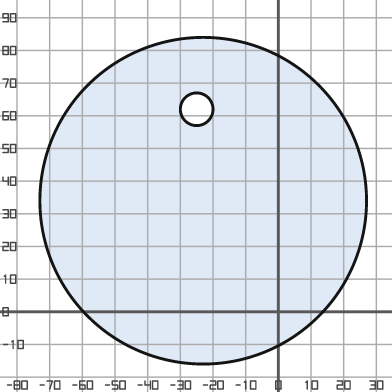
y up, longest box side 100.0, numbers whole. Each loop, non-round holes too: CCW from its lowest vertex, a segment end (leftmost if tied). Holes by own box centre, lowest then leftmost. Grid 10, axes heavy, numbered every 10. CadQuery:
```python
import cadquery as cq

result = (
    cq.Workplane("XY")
    .moveTo(-23.0, 34.0)
    .circle(50.0)
    .moveTo(-25.0, 62.0)
    .circle(5.0)
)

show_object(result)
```